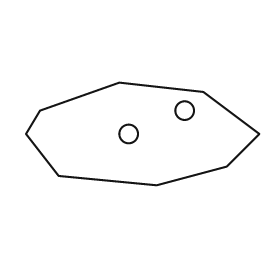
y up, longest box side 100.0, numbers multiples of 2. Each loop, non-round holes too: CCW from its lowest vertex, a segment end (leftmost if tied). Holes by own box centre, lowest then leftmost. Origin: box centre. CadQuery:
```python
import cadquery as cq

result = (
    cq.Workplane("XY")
    .moveTo(6.0, -22.0)
    .lineTo(36.0, -14.0)
    .lineTo(50.0, 0.0)
    .lineTo(26.0, 18.0)
    .lineTo(-10.0, 22.0)
    .lineTo(-44.0, 10.0)
    .lineTo(-50.0, 0.0)
    .lineTo(-36.0, -18.0)
    .close()
    .moveTo(-6.0, 0.0)
    .circle(4.0)
    .moveTo(18.0, 10.0)
    .circle(4.0)
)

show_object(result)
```